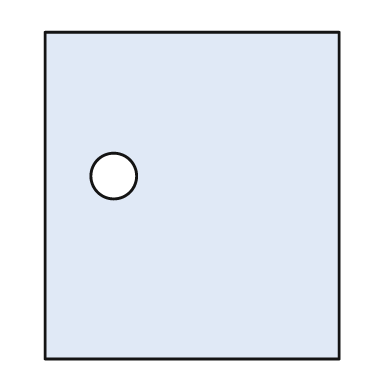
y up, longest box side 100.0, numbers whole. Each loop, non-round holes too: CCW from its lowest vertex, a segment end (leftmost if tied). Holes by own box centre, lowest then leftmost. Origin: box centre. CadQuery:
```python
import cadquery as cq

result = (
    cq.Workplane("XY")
    .moveTo(-45.0, -50.0)
    .lineTo(45.0, -50.0)
    .lineTo(45.0, 50.0)
    .lineTo(-45.0, 50.0)
    .close()
    .moveTo(-24.0, 6.0)
    .circle(7.0)
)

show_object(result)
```